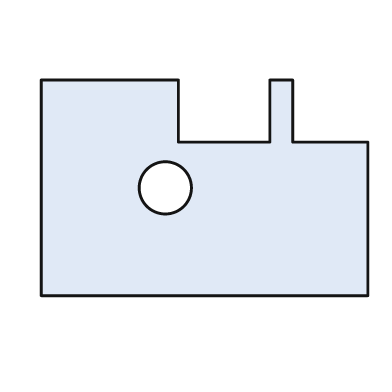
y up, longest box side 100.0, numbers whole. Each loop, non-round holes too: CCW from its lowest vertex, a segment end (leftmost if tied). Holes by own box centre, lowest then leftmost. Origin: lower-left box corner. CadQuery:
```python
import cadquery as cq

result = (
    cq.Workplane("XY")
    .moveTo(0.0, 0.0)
    .lineTo(100.0, 0.0)
    .lineTo(100.0, 47.0)
    .lineTo(77.0, 47.0)
    .lineTo(77.0, 66.0)
    .lineTo(70.0, 66.0)
    .lineTo(70.0, 47.0)
    .lineTo(42.0, 47.0)
    .lineTo(42.0, 66.0)
    .lineTo(0.0, 66.0)
    .close()
    .moveTo(38.0, 33.0)
    .circle(8.0)
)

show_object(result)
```